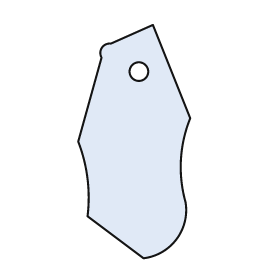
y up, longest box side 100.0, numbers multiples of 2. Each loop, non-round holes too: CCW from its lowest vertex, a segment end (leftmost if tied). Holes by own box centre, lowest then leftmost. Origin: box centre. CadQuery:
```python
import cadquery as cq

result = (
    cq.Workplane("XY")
    .moveTo(4.0, -50.0)
    .threePointArc((18.0, -42.0), (22.0, -26.0))
    .threePointArc((20.0, -8.0), (24.0, 10.0))
    .lineTo(8.0, 50.0)
    .lineTo(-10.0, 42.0)
    .threePointArc((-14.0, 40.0), (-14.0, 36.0))
    .lineTo(-24.0, 0.0)
    .threePointArc((-20.0, -16.0), (-20.0, -32.0))
    .close()
    .moveTo(2.0, 30.0)
    .circle(4.0)
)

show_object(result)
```